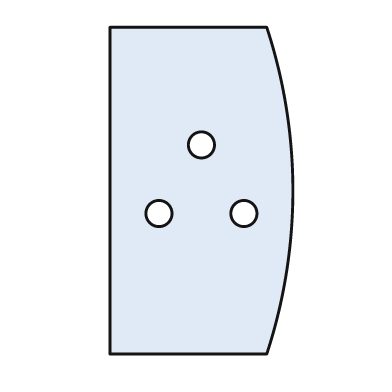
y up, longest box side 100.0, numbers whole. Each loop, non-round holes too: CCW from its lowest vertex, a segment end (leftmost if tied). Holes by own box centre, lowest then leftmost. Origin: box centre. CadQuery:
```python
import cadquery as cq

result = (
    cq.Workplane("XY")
    .moveTo(-28.0, -50.0)
    .lineTo(20.0, -50.0)
    .threePointArc((28.0, 0.0), (20.0, 50.0))
    .lineTo(-28.0, 50.0)
    .close()
    .moveTo(-13.0, -7.0)
    .circle(4.0)
    .moveTo(13.0, -7.0)
    .circle(4.0)
    .moveTo(0.0, 14.0)
    .circle(4.0)
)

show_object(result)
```